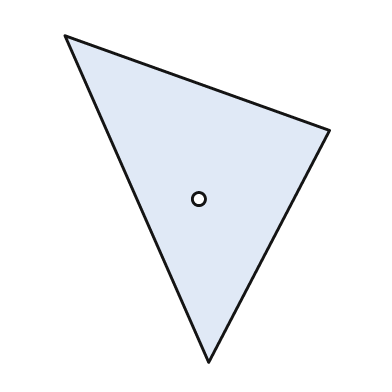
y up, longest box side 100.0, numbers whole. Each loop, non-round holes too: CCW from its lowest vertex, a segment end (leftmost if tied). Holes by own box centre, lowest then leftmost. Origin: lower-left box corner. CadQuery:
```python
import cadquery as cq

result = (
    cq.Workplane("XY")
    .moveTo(44.0, 0.0)
    .lineTo(81.0, 71.0)
    .lineTo(0.0, 100.0)
    .close()
    .moveTo(41.0, 50.0)
    .circle(2.0)
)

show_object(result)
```